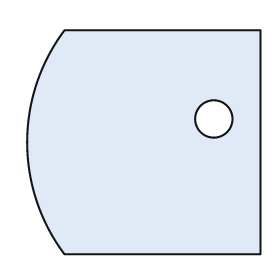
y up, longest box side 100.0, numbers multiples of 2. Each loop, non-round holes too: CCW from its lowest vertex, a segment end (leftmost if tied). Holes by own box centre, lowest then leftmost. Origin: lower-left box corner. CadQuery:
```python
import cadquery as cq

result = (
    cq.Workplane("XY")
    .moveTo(16.0, 0.0)
    .lineTo(100.0, 0.0)
    .lineTo(100.0, 96.0)
    .lineTo(16.0, 96.0)
    .threePointArc((0.0, 48.0), (16.0, 0.0))
    .close()
    .moveTo(80.0, 58.0)
    .circle(8.0)
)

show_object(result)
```